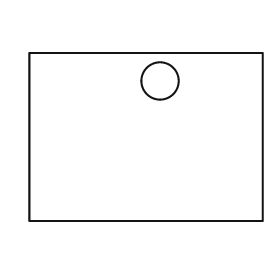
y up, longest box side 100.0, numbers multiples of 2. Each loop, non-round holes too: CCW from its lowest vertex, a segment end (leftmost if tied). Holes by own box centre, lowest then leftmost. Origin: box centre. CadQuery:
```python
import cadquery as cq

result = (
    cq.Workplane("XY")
    .moveTo(-50.0, -36.0)
    .lineTo(50.0, -36.0)
    .lineTo(50.0, 36.0)
    .lineTo(-50.0, 36.0)
    .close()
    .moveTo(6.0, 24.0)
    .circle(8.0)
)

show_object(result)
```